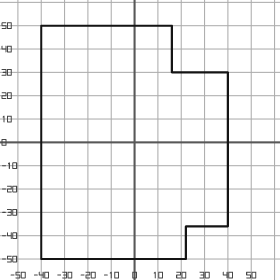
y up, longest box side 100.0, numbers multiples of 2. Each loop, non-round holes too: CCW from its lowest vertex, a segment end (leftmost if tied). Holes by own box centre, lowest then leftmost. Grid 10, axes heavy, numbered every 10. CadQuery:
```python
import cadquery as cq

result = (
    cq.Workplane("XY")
    .moveTo(-40.0, -50.0)
    .lineTo(22.0, -50.0)
    .lineTo(22.0, -36.0)
    .lineTo(40.0, -36.0)
    .lineTo(40.0, 30.0)
    .lineTo(16.0, 30.0)
    .lineTo(16.0, 50.0)
    .lineTo(-40.0, 50.0)
    .close()
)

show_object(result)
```